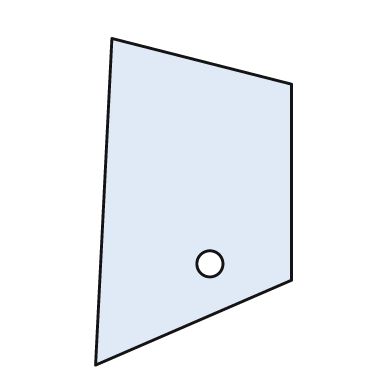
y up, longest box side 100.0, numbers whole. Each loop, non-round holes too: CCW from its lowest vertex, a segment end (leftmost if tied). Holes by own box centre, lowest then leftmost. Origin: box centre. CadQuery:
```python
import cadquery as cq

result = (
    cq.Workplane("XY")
    .moveTo(-30.0, -50.0)
    .lineTo(30.0, -24.0)
    .lineTo(30.0, 36.0)
    .lineTo(-25.0, 50.0)
    .close()
    .moveTo(5.0, -19.0)
    .circle(4.0)
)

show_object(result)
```